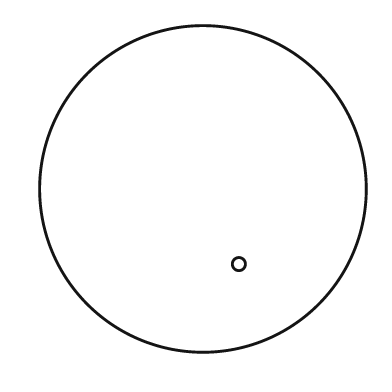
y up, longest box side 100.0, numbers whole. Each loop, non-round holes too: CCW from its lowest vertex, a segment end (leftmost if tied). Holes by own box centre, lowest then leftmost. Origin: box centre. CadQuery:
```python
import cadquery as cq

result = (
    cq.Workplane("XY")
    .moveTo(0.0, 0.0)
    .circle(50.0)
    .moveTo(11.0, -23.0)
    .circle(2.0)
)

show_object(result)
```